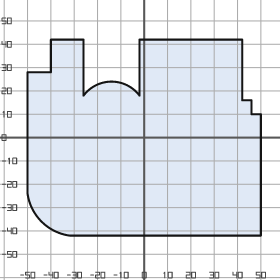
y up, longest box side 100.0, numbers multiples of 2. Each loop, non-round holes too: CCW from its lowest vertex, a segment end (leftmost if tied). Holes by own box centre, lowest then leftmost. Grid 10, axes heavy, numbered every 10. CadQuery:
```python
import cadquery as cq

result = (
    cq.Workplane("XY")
    .moveTo(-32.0, -42.0)
    .lineTo(50.0, -42.0)
    .lineTo(50.0, 10.0)
    .lineTo(46.0, 10.0)
    .lineTo(46.0, 16.0)
    .lineTo(42.0, 16.0)
    .lineTo(42.0, 42.0)
    .lineTo(-2.0, 42.0)
    .lineTo(-2.0, 18.0)
    .threePointArc((-14.0, 24.0), (-26.0, 18.0))
    .lineTo(-26.0, 42.0)
    .lineTo(-40.0, 42.0)
    .lineTo(-40.0, 28.0)
    .lineTo(-50.0, 28.0)
    .lineTo(-50.0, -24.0)
    .threePointArc((-44.0, -36.0), (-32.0, -42.0))
    .close()
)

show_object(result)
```